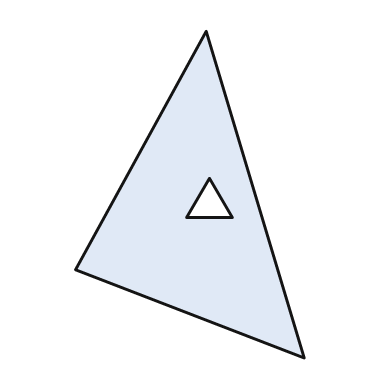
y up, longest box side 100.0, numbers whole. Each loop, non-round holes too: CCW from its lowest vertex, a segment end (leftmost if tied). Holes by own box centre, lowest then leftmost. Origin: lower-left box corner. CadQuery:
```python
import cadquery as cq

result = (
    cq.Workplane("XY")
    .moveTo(70.0, 0.0)
    .lineTo(40.0, 100.0)
    .lineTo(0.0, 27.0)
    .close()
    .moveTo(34.0, 43.0)
    .lineTo(48.0, 43.0)
    .lineTo(41.0, 55.0)
    .close()
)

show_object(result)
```